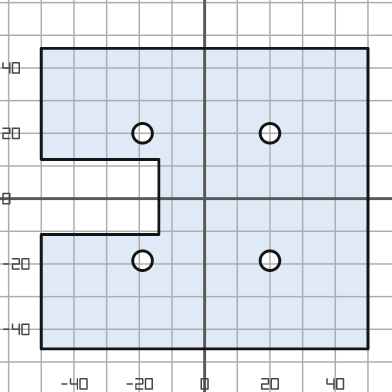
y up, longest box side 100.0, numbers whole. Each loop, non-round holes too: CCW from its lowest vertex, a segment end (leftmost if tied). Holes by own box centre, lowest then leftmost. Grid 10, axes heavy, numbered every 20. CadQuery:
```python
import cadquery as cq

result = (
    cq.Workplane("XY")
    .moveTo(-50.0, -46.0)
    .lineTo(50.0, -46.0)
    .lineTo(50.0, 46.0)
    .lineTo(-50.0, 46.0)
    .lineTo(-50.0, 12.0)
    .lineTo(-14.0, 12.0)
    .lineTo(-14.0, -11.0)
    .lineTo(-50.0, -11.0)
    .close()
    .moveTo(-19.0, -19.0)
    .circle(3.0)
    .moveTo(20.0, -19.0)
    .circle(3.0)
    .moveTo(-19.0, 20.0)
    .circle(3.0)
    .moveTo(20.0, 20.0)
    .circle(3.0)
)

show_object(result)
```